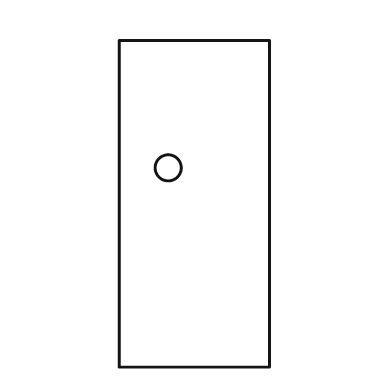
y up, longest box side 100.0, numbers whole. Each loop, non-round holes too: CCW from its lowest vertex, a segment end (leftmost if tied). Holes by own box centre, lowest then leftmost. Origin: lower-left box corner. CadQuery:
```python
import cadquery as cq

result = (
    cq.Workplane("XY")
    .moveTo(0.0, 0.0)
    .lineTo(46.0, 0.0)
    .lineTo(46.0, 100.0)
    .lineTo(0.0, 100.0)
    .close()
    .moveTo(15.0, 61.0)
    .circle(4.0)
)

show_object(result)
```